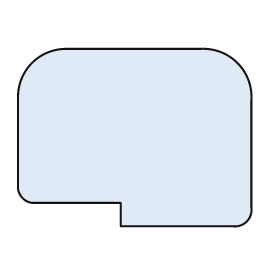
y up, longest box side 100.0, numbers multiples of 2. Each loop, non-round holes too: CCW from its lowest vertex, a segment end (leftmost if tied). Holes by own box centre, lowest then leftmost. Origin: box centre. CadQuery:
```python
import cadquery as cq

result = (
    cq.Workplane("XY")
    .moveTo(-6.0, -38.0)
    .lineTo(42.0, -38.0)
    .threePointArc((48.0, -36.0), (50.0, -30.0))
    .lineTo(50.0, 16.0)
    .threePointArc((44.0, 32.0), (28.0, 38.0))
    .lineTo(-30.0, 38.0)
    .threePointArc((-44.0, 32.0), (-50.0, 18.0))
    .lineTo(-50.0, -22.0)
    .threePointArc((-48.0, -26.0), (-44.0, -28.0))
    .lineTo(-6.0, -28.0)
    .close()
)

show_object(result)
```